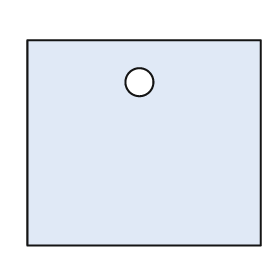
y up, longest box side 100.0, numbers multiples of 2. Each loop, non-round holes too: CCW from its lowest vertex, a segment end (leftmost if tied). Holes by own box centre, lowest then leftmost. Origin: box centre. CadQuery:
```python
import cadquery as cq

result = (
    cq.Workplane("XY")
    .moveTo(-50.0, -44.0)
    .lineTo(50.0, -44.0)
    .lineTo(50.0, 44.0)
    .lineTo(-50.0, 44.0)
    .close()
    .moveTo(-2.0, 26.0)
    .circle(6.0)
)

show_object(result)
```